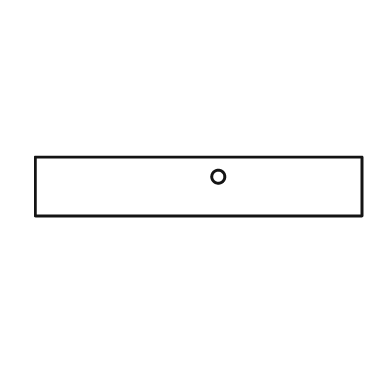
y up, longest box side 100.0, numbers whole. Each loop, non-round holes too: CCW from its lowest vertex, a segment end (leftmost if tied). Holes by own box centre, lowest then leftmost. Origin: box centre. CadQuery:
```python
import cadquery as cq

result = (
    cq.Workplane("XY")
    .moveTo(-50.0, -9.0)
    .lineTo(50.0, -9.0)
    .lineTo(50.0, 9.0)
    .lineTo(-50.0, 9.0)
    .close()
    .moveTo(6.0, 3.0)
    .circle(2.0)
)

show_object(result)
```